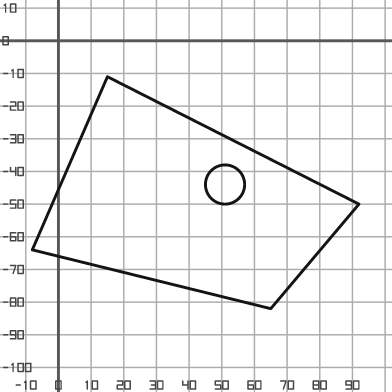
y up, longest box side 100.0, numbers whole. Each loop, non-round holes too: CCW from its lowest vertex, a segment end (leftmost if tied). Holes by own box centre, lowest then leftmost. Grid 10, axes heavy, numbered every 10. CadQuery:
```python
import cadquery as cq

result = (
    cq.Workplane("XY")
    .moveTo(65.0, -82.0)
    .lineTo(92.0, -50.0)
    .lineTo(15.0, -11.0)
    .lineTo(-8.0, -64.0)
    .close()
    .moveTo(51.0, -44.0)
    .circle(6.0)
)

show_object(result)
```